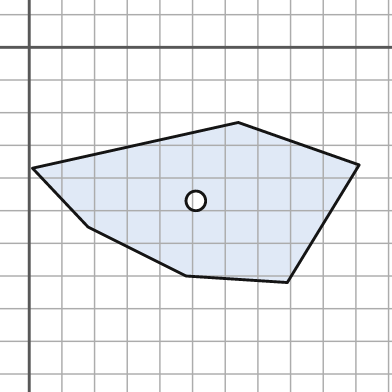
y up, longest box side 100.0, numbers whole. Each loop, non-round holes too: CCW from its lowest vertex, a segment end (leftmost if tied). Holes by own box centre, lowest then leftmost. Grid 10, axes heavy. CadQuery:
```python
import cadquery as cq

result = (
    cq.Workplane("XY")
    .moveTo(79.0, -72.0)
    .lineTo(101.0, -36.0)
    .lineTo(64.0, -23.0)
    .lineTo(1.0, -37.0)
    .lineTo(18.0, -55.0)
    .lineTo(48.0, -70.0)
    .close()
    .moveTo(51.0, -47.0)
    .circle(3.0)
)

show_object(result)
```